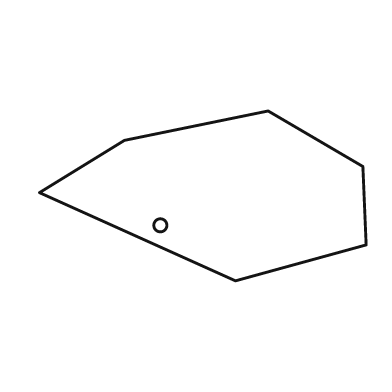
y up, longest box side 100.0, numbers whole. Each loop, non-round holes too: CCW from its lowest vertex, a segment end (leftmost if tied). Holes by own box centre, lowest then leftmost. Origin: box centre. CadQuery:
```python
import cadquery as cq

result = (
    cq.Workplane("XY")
    .moveTo(10.0, -26.0)
    .lineTo(50.0, -15.0)
    .lineTo(49.0, 9.0)
    .lineTo(20.0, 26.0)
    .lineTo(-24.0, 17.0)
    .lineTo(-50.0, 1.0)
    .close()
    .moveTo(-13.0, -9.0)
    .circle(2.0)
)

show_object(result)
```